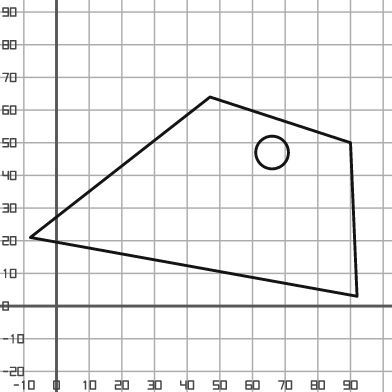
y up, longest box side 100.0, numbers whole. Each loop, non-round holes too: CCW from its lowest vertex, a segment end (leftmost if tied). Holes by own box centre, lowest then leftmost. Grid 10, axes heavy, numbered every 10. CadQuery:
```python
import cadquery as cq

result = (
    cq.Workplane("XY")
    .moveTo(92.0, 3.0)
    .lineTo(90.0, 50.0)
    .lineTo(47.0, 64.0)
    .lineTo(-8.0, 21.0)
    .close()
    .moveTo(66.0, 47.0)
    .circle(5.0)
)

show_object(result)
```